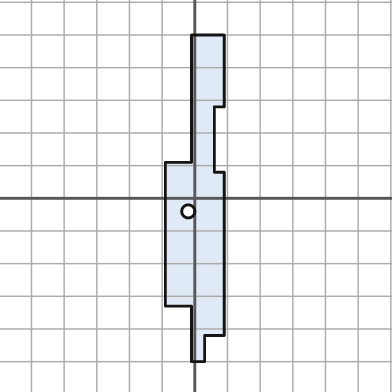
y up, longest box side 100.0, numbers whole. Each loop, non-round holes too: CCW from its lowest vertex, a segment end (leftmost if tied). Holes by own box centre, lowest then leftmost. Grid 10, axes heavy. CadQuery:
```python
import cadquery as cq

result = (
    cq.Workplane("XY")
    .moveTo(-1.0, -50.0)
    .lineTo(3.0, -50.0)
    .lineTo(3.0, -42.0)
    .lineTo(9.0, -42.0)
    .lineTo(9.0, 8.0)
    .lineTo(6.0, 8.0)
    .lineTo(6.0, 28.0)
    .lineTo(9.0, 28.0)
    .lineTo(9.0, 50.0)
    .lineTo(-1.0, 50.0)
    .lineTo(-1.0, 11.0)
    .lineTo(-9.0, 11.0)
    .lineTo(-9.0, -33.0)
    .lineTo(-1.0, -33.0)
    .close()
    .moveTo(-2.0, -4.0)
    .circle(2.0)
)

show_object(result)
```